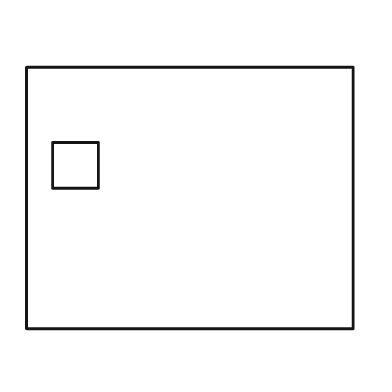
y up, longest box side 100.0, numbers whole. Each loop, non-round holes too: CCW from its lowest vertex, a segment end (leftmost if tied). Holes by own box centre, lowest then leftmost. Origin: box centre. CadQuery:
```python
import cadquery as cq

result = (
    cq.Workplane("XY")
    .moveTo(-50.0, -40.0)
    .lineTo(50.0, -40.0)
    .lineTo(50.0, 40.0)
    .lineTo(-50.0, 40.0)
    .close()
    .moveTo(-42.0, 3.0)
    .lineTo(-28.0, 3.0)
    .lineTo(-28.0, 17.0)
    .lineTo(-42.0, 17.0)
    .close()
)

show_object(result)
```